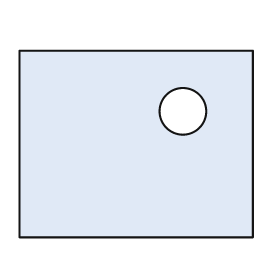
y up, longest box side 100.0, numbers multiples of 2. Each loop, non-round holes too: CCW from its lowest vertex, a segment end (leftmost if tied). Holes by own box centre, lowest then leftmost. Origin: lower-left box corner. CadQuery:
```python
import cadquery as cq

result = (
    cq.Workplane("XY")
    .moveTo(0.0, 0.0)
    .lineTo(100.0, 0.0)
    .lineTo(100.0, 80.0)
    .lineTo(0.0, 80.0)
    .close()
    .moveTo(70.0, 54.0)
    .circle(10.0)
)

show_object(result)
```